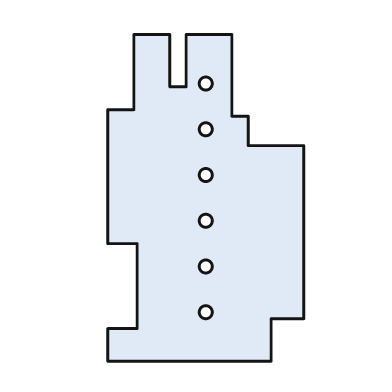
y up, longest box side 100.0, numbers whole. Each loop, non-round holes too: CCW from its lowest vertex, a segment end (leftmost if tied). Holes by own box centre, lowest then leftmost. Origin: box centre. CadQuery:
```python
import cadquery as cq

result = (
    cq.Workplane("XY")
    .moveTo(-30.0, -50.0)
    .lineTo(20.0, -50.0)
    .lineTo(20.0, -37.0)
    .lineTo(30.0, -37.0)
    .lineTo(30.0, 16.0)
    .lineTo(13.0, 16.0)
    .lineTo(13.0, 25.0)
    .lineTo(8.0, 25.0)
    .lineTo(8.0, 50.0)
    .lineTo(-6.0, 50.0)
    .lineTo(-6.0, 34.0)
    .lineTo(-11.0, 34.0)
    .lineTo(-11.0, 50.0)
    .lineTo(-22.0, 50.0)
    .lineTo(-22.0, 27.0)
    .lineTo(-30.0, 27.0)
    .lineTo(-30.0, -14.0)
    .lineTo(-21.0, -14.0)
    .lineTo(-21.0, -40.0)
    .lineTo(-30.0, -40.0)
    .close()
    .moveTo(0.0, -35.0)
    .circle(2.0)
    .moveTo(0.0, -21.0)
    .circle(2.0)
    .moveTo(0.0, -7.0)
    .circle(2.0)
    .moveTo(0.0, 7.0)
    .circle(2.0)
    .moveTo(0.0, 21.0)
    .circle(2.0)
    .moveTo(0.0, 35.0)
    .circle(2.0)
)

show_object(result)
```